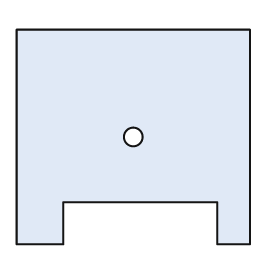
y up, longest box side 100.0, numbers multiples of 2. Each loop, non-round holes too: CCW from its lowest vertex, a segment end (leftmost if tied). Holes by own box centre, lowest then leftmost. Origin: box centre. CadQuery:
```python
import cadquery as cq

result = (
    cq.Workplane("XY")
    .moveTo(-50.0, -46.0)
    .lineTo(-30.0, -46.0)
    .lineTo(-30.0, -28.0)
    .lineTo(36.0, -28.0)
    .lineTo(36.0, -46.0)
    .lineTo(50.0, -46.0)
    .lineTo(50.0, 46.0)
    .lineTo(-50.0, 46.0)
    .close()
    .moveTo(0.0, 0.0)
    .circle(4.0)
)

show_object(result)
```